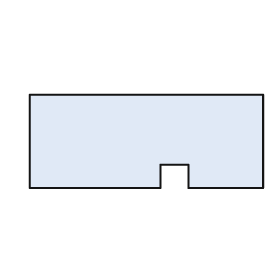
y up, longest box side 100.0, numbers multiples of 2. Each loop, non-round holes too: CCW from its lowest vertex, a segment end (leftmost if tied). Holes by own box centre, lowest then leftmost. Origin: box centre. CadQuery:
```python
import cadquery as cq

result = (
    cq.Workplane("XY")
    .moveTo(-50.0, -20.0)
    .lineTo(6.0, -20.0)
    .lineTo(6.0, -10.0)
    .lineTo(18.0, -10.0)
    .lineTo(18.0, -20.0)
    .lineTo(50.0, -20.0)
    .lineTo(50.0, 20.0)
    .lineTo(-50.0, 20.0)
    .close()
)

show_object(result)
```